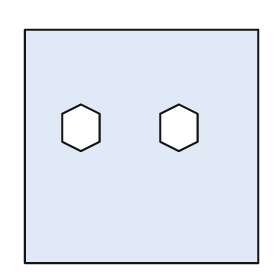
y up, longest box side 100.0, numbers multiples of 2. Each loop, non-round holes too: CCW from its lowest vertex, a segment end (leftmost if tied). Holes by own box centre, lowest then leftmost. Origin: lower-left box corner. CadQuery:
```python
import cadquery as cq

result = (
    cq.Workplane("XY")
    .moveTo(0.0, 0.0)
    .lineTo(100.0, 0.0)
    .lineTo(100.0, 100.0)
    .lineTo(0.0, 100.0)
    .close()
    .moveTo(24.0, 48.0)
    .lineTo(32.0, 52.0)
    .lineTo(32.0, 64.0)
    .lineTo(24.0, 68.0)
    .lineTo(16.0, 64.0)
    .lineTo(16.0, 52.0)
    .close()
    .moveTo(66.0, 48.0)
    .lineTo(74.0, 52.0)
    .lineTo(74.0, 64.0)
    .lineTo(66.0, 68.0)
    .lineTo(58.0, 64.0)
    .lineTo(58.0, 52.0)
    .close()
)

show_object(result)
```